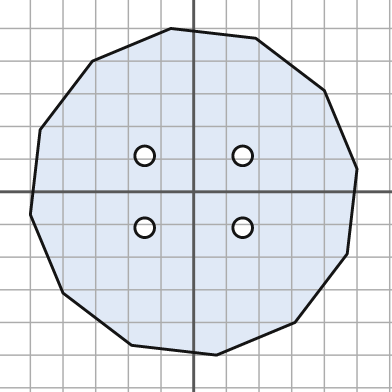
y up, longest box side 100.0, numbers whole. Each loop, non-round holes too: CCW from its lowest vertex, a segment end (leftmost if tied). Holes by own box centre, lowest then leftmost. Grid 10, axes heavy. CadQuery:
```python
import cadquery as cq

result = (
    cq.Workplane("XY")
    .moveTo(7.0, -50.0)
    .lineTo(31.0, -40.0)
    .lineTo(47.0, -19.0)
    .lineTo(50.0, 7.0)
    .lineTo(40.0, 31.0)
    .lineTo(19.0, 47.0)
    .lineTo(-7.0, 50.0)
    .lineTo(-31.0, 40.0)
    .lineTo(-47.0, 19.0)
    .lineTo(-50.0, -7.0)
    .lineTo(-40.0, -31.0)
    .lineTo(-19.0, -47.0)
    .close()
    .moveTo(-15.0, -11.0)
    .circle(3.0)
    .moveTo(15.0, -11.0)
    .circle(3.0)
    .moveTo(-15.0, 11.0)
    .circle(3.0)
    .moveTo(15.0, 11.0)
    .circle(3.0)
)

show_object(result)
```